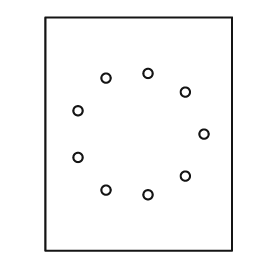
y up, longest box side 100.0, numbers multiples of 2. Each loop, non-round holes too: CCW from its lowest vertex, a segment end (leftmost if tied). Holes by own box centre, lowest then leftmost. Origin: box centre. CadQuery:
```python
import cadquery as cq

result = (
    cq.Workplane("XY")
    .moveTo(-40.0, -50.0)
    .lineTo(40.0, -50.0)
    .lineTo(40.0, 50.0)
    .lineTo(-40.0, 50.0)
    .close()
    .moveTo(4.0, -26.0)
    .circle(2.0)
    .moveTo(-14.0, -24.0)
    .circle(2.0)
    .moveTo(20.0, -18.0)
    .circle(2.0)
    .moveTo(-26.0, -10.0)
    .circle(2.0)
    .moveTo(28.0, 0.0)
    .circle(2.0)
    .moveTo(-26.0, 10.0)
    .circle(2.0)
    .moveTo(20.0, 18.0)
    .circle(2.0)
    .moveTo(-14.0, 24.0)
    .circle(2.0)
    .moveTo(4.0, 26.0)
    .circle(2.0)
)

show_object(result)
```